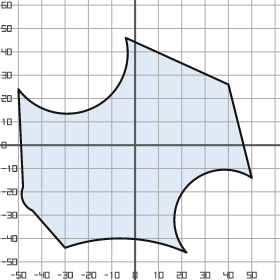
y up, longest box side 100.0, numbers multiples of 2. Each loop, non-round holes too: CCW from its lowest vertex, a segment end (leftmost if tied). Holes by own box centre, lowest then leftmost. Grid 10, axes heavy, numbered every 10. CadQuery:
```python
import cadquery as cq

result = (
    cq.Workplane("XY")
    .moveTo(22.0, -46.0)
    .threePointArc((22.0, -18.0), (50.0, -14.0))
    .lineTo(40.0, 26.0)
    .lineTo(-4.0, 46.0)
    .threePointArc((-18.0, 16.0), (-50.0, 24.0))
    .lineTo(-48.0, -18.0)
    .threePointArc((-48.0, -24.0), (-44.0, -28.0))
    .lineTo(-30.0, -44.0)
    .threePointArc((-4.0, -40.0), (22.0, -46.0))
    .close()
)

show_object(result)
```